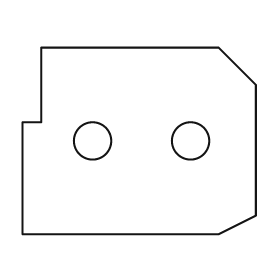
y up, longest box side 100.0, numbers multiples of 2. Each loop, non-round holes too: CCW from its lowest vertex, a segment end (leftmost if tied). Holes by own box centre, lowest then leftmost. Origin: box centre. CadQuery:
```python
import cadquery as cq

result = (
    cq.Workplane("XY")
    .moveTo(-50.0, -40.0)
    .lineTo(34.0, -40.0)
    .lineTo(50.0, -32.0)
    .lineTo(50.0, 24.0)
    .lineTo(34.0, 40.0)
    .lineTo(-42.0, 40.0)
    .lineTo(-42.0, 8.0)
    .lineTo(-50.0, 8.0)
    .close()
    .moveTo(-20.0, 0.0)
    .circle(8.0)
    .moveTo(22.0, 0.0)
    .circle(8.0)
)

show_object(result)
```